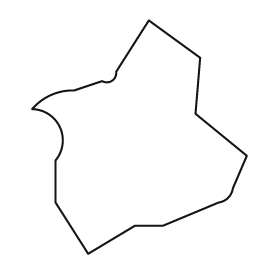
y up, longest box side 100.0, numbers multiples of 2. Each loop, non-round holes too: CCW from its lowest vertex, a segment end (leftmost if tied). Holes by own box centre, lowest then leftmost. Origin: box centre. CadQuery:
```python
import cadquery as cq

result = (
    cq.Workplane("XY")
    .moveTo(-22.0, -50.0)
    .lineTo(-2.0, -38.0)
    .lineTo(10.0, -38.0)
    .lineTo(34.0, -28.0)
    .threePointArc((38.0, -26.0), (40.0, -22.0))
    .lineTo(46.0, -8.0)
    .lineTo(24.0, 10.0)
    .lineTo(26.0, 34.0)
    .lineTo(4.0, 50.0)
    .lineTo(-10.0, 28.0)
    .threePointArc((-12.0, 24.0), (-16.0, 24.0))
    .lineTo(-28.0, 20.0)
    .threePointArc((-38.0, 18.0), (-46.0, 12.0))
    .threePointArc((-34.0, 4.0), (-36.0, -10.0))
    .lineTo(-36.0, -28.0)
    .close()
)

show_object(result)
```